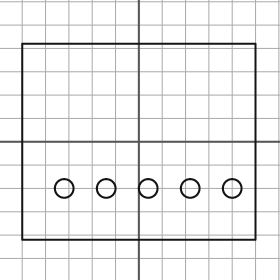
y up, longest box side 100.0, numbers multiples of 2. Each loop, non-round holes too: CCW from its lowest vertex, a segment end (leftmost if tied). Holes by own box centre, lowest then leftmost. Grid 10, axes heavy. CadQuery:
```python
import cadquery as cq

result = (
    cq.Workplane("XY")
    .moveTo(-50.0, -42.0)
    .lineTo(50.0, -42.0)
    .lineTo(50.0, 42.0)
    .lineTo(-50.0, 42.0)
    .close()
    .moveTo(-32.0, -20.0)
    .circle(4.0)
    .moveTo(-14.0, -20.0)
    .circle(4.0)
    .moveTo(4.0, -20.0)
    .circle(4.0)
    .moveTo(22.0, -20.0)
    .circle(4.0)
    .moveTo(40.0, -20.0)
    .circle(4.0)
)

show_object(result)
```